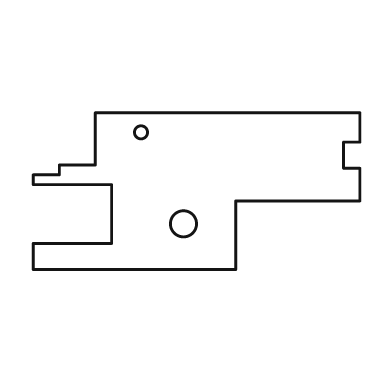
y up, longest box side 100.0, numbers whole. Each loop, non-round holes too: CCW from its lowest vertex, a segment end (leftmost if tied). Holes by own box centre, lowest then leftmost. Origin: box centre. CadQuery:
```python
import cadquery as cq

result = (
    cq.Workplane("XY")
    .moveTo(-50.0, -24.0)
    .lineTo(12.0, -24.0)
    .lineTo(12.0, -3.0)
    .lineTo(50.0, -3.0)
    .lineTo(50.0, 7.0)
    .lineTo(45.0, 7.0)
    .lineTo(45.0, 15.0)
    .lineTo(50.0, 15.0)
    .lineTo(50.0, 24.0)
    .lineTo(-31.0, 24.0)
    .lineTo(-31.0, 8.0)
    .lineTo(-42.0, 8.0)
    .lineTo(-42.0, 5.0)
    .lineTo(-50.0, 5.0)
    .lineTo(-50.0, 2.0)
    .lineTo(-26.0, 2.0)
    .lineTo(-26.0, -16.0)
    .lineTo(-50.0, -16.0)
    .close()
    .moveTo(-4.0, -10.0)
    .circle(4.0)
    .moveTo(-17.0, 18.0)
    .circle(2.0)
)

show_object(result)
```